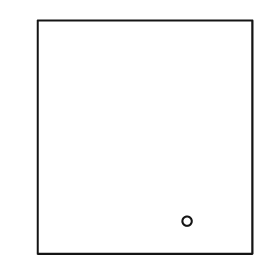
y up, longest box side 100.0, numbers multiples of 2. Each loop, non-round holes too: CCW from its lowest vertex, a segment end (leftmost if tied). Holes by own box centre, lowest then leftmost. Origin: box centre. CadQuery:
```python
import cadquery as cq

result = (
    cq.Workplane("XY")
    .moveTo(-46.0, -50.0)
    .lineTo(46.0, -50.0)
    .lineTo(46.0, 50.0)
    .lineTo(-46.0, 50.0)
    .close()
    .moveTo(18.0, -36.0)
    .circle(2.0)
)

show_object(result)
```